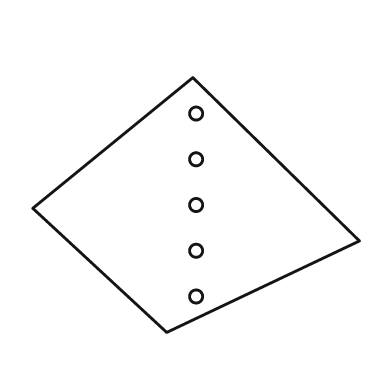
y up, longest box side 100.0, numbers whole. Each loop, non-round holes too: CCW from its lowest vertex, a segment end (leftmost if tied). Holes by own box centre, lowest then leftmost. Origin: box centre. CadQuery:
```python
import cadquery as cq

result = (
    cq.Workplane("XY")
    .moveTo(-9.0, -39.0)
    .lineTo(50.0, -11.0)
    .lineTo(-1.0, 39.0)
    .lineTo(-50.0, -1.0)
    .close()
    .moveTo(0.0, -28.0)
    .circle(2.0)
    .moveTo(0.0, -14.0)
    .circle(2.0)
    .moveTo(0.0, 0.0)
    .circle(2.0)
    .moveTo(0.0, 14.0)
    .circle(2.0)
    .moveTo(0.0, 28.0)
    .circle(2.0)
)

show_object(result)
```